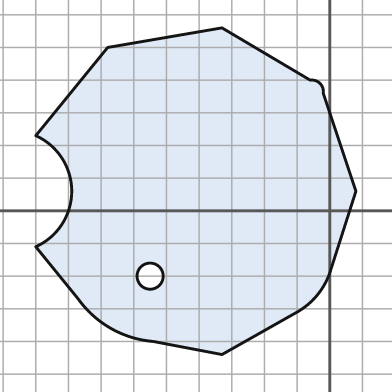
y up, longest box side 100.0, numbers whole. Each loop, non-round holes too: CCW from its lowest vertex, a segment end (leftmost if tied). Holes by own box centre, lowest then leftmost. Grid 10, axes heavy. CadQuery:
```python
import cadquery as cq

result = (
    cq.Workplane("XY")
    .moveTo(-33.0, -44.0)
    .lineTo(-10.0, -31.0)
    .threePointArc((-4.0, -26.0), (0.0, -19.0))
    .lineTo(8.0, 6.0)
    .lineTo(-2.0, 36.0)
    .threePointArc((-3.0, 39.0), (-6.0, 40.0))
    .lineTo(-33.0, 56.0)
    .lineTo(-68.0, 50.0)
    .lineTo(-90.0, 23.0)
    .threePointArc((-79.0, 6.0), (-90.0, -11.0))
    .lineTo(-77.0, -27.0)
    .threePointArc((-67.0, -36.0), (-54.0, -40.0))
    .close()
    .moveTo(-55.0, -20.0)
    .circle(4.0)
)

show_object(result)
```